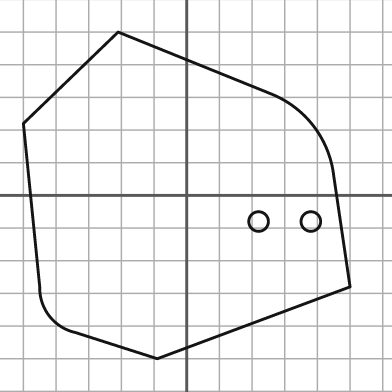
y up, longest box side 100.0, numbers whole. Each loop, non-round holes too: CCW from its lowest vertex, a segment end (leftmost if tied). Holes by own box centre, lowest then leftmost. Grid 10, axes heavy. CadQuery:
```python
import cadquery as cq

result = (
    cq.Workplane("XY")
    .moveTo(-9.0, -50.0)
    .lineTo(50.0, -28.0)
    .lineTo(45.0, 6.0)
    .threePointArc((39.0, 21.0), (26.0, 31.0))
    .lineTo(-21.0, 50.0)
    .lineTo(-50.0, 22.0)
    .lineTo(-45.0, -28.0)
    .threePointArc((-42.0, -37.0), (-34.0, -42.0))
    .close()
    .moveTo(22.0, -8.0)
    .circle(3.0)
    .moveTo(38.0, -8.0)
    .circle(3.0)
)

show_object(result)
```